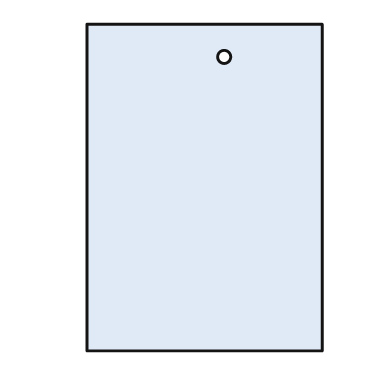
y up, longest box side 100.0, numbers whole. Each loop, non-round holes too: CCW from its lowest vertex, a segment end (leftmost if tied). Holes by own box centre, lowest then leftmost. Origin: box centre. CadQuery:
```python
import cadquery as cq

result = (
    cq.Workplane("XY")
    .moveTo(-36.0, -50.0)
    .lineTo(36.0, -50.0)
    .lineTo(36.0, 50.0)
    .lineTo(-36.0, 50.0)
    .close()
    .moveTo(6.0, 40.0)
    .circle(2.0)
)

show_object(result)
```